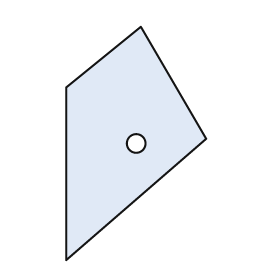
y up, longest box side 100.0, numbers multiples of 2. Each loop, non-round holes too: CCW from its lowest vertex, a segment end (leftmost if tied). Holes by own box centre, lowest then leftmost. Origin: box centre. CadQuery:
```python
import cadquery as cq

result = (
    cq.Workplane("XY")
    .moveTo(-30.0, -50.0)
    .lineTo(30.0, 2.0)
    .lineTo(2.0, 50.0)
    .lineTo(-30.0, 24.0)
    .close()
    .moveTo(0.0, 0.0)
    .circle(4.0)
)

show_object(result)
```